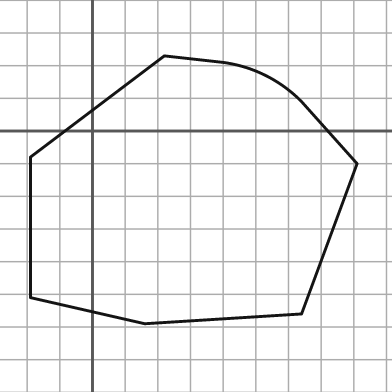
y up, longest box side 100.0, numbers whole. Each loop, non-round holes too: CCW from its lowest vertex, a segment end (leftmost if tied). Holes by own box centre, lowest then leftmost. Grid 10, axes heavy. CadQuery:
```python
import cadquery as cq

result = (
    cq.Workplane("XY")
    .moveTo(16.0, -59.0)
    .lineTo(64.0, -56.0)
    .lineTo(81.0, -10.0)
    .lineTo(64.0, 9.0)
    .threePointArc((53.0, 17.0), (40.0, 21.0))
    .lineTo(22.0, 23.0)
    .lineTo(-19.0, -8.0)
    .lineTo(-19.0, -51.0)
    .close()
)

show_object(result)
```